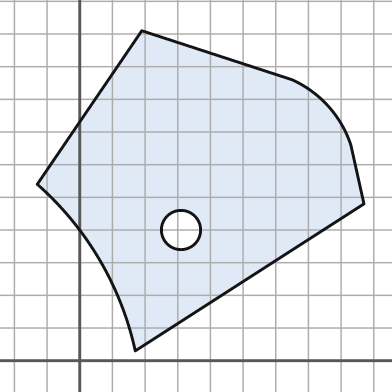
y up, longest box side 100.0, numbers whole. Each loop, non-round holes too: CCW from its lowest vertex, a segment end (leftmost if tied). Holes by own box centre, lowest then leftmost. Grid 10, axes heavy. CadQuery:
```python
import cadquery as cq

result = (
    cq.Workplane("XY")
    .moveTo(17.0, 3.0)
    .lineTo(87.0, 48.0)
    .lineTo(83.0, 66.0)
    .threePointArc((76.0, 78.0), (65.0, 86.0))
    .lineTo(19.0, 101.0)
    .lineTo(-13.0, 54.0)
    .threePointArc((6.0, 31.0), (17.0, 3.0))
    .close()
    .moveTo(31.0, 40.0)
    .circle(6.0)
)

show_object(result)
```